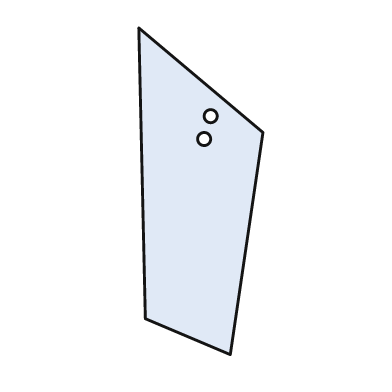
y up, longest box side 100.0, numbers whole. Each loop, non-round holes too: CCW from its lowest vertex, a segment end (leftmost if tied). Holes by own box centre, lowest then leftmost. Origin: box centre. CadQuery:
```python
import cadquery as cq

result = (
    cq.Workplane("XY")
    .moveTo(9.0, -50.0)
    .lineTo(19.0, 18.0)
    .lineTo(-19.0, 50.0)
    .lineTo(-17.0, -39.0)
    .close()
    .moveTo(1.0, 16.0)
    .circle(2.0)
    .moveTo(3.0, 23.0)
    .circle(2.0)
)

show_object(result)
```